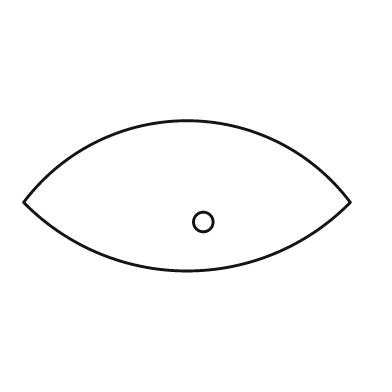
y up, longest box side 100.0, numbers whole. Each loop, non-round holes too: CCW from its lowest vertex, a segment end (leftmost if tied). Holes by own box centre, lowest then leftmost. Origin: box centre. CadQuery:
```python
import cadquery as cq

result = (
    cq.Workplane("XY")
    .moveTo(-50.0, -2.0)
    .threePointArc((0.0, -23.0), (50.0, -2.0))
    .threePointArc((0.0, 23.0), (-50.0, -2.0))
    .close()
    .moveTo(5.0, -8.0)
    .circle(3.0)
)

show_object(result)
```